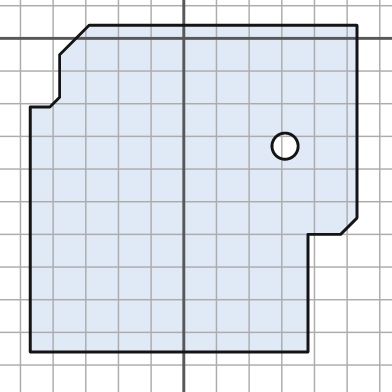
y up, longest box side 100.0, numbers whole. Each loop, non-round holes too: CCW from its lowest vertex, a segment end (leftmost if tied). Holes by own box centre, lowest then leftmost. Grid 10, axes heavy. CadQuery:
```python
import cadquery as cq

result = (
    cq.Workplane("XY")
    .moveTo(-47.0, -96.0)
    .lineTo(38.0, -96.0)
    .lineTo(38.0, -60.0)
    .lineTo(48.0, -60.0)
    .lineTo(53.0, -55.0)
    .lineTo(53.0, 4.0)
    .lineTo(-29.0, 4.0)
    .lineTo(-38.0, -5.0)
    .lineTo(-38.0, -18.0)
    .lineTo(-41.0, -21.0)
    .lineTo(-47.0, -21.0)
    .close()
    .moveTo(31.0, -33.0)
    .circle(4.0)
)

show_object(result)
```